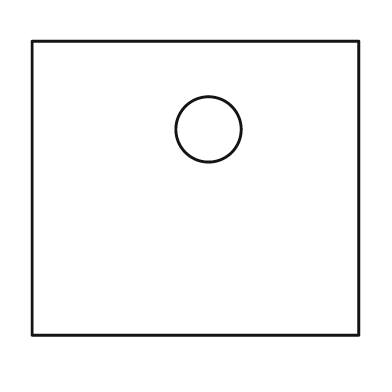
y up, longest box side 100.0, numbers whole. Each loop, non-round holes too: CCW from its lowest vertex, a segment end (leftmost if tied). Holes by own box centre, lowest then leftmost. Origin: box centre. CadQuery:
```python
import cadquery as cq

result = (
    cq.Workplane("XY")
    .moveTo(-50.0, -45.0)
    .lineTo(50.0, -45.0)
    .lineTo(50.0, 45.0)
    .lineTo(-50.0, 45.0)
    .close()
    .moveTo(4.0, 18.0)
    .circle(10.0)
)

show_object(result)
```